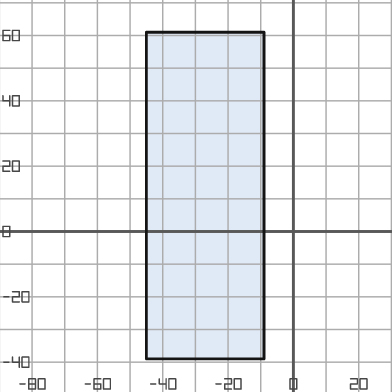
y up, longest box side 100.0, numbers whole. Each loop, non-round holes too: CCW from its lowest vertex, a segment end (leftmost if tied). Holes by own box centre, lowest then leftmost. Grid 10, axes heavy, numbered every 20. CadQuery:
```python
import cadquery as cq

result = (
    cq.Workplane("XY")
    .moveTo(-45.0, -39.0)
    .lineTo(-9.0, -39.0)
    .lineTo(-9.0, 61.0)
    .lineTo(-45.0, 61.0)
    .close()
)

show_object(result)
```